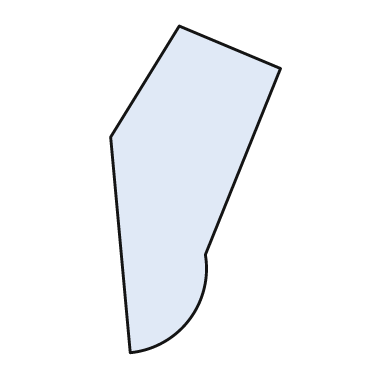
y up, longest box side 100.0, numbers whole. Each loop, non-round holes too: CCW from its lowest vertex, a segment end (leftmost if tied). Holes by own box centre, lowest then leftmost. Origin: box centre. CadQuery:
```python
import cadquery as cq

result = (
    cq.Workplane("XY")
    .moveTo(-20.0, -50.0)
    .threePointArc((-2.0, -40.0), (3.0, -20.0))
    .lineTo(26.0, 37.0)
    .lineTo(-5.0, 50.0)
    .lineTo(-26.0, 16.0)
    .close()
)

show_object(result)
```